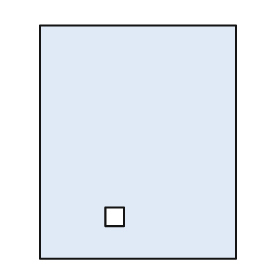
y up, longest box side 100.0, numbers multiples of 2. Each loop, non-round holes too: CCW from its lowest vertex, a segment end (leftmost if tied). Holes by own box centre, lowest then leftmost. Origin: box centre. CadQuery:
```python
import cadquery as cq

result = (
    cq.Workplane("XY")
    .moveTo(-42.0, -50.0)
    .lineTo(42.0, -50.0)
    .lineTo(42.0, 50.0)
    .lineTo(-42.0, 50.0)
    .close()
    .moveTo(-14.0, -36.0)
    .lineTo(-6.0, -36.0)
    .lineTo(-6.0, -28.0)
    .lineTo(-14.0, -28.0)
    .close()
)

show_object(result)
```